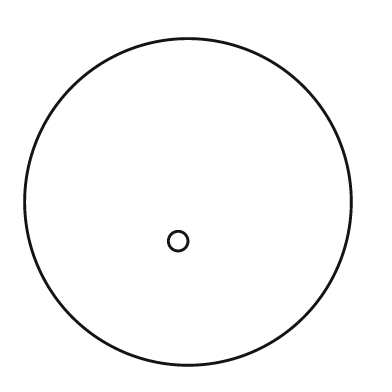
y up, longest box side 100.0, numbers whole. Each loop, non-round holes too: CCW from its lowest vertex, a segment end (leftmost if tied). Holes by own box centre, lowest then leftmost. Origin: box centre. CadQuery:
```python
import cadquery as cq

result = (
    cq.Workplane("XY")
    .moveTo(0.0, 0.0)
    .circle(50.0)
    .moveTo(-3.0, -12.0)
    .circle(3.0)
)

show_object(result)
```